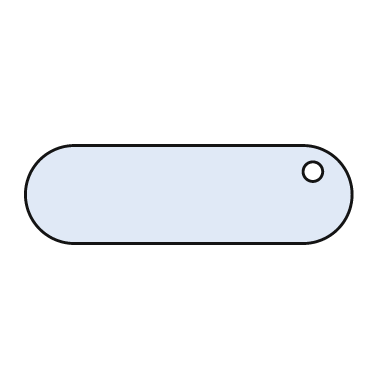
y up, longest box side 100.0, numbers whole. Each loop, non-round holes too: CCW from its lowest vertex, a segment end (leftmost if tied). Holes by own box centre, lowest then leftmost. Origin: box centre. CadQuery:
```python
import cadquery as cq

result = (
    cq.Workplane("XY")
    .moveTo(-35.0, -15.0)
    .lineTo(35.0, -15.0)
    .threePointArc((50.0, 0.0), (35.0, 15.0))
    .lineTo(-35.0, 15.0)
    .threePointArc((-50.0, 0.0), (-35.0, -15.0))
    .close()
    .moveTo(38.0, 7.0)
    .circle(3.0)
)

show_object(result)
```